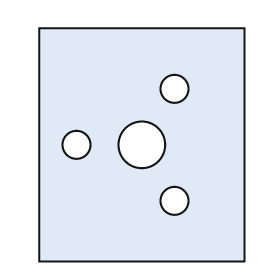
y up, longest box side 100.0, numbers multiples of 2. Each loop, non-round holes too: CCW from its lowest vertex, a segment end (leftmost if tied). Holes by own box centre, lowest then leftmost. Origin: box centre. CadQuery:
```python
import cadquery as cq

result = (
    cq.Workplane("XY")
    .moveTo(-44.0, -50.0)
    .lineTo(44.0, -50.0)
    .lineTo(44.0, 50.0)
    .lineTo(-44.0, 50.0)
    .close()
    .moveTo(14.0, -24.0)
    .circle(6.0)
    .moveTo(-28.0, 0.0)
    .circle(6.0)
    .moveTo(0.0, 0.0)
    .circle(10.0)
    .moveTo(14.0, 24.0)
    .circle(6.0)
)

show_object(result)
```